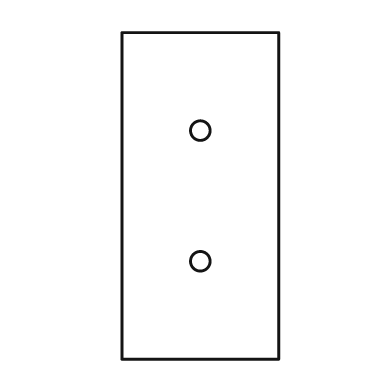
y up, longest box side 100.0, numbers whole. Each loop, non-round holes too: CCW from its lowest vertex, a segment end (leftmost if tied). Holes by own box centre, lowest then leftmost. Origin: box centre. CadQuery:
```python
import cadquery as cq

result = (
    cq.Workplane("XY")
    .moveTo(-24.0, -50.0)
    .lineTo(24.0, -50.0)
    .lineTo(24.0, 50.0)
    .lineTo(-24.0, 50.0)
    .close()
    .moveTo(0.0, -20.0)
    .circle(3.0)
    .moveTo(0.0, 20.0)
    .circle(3.0)
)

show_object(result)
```